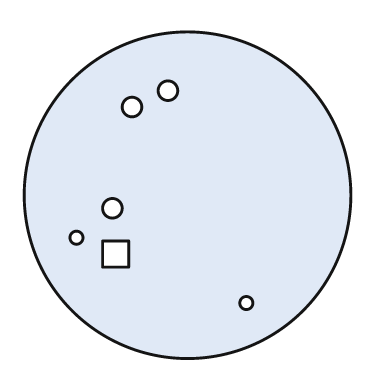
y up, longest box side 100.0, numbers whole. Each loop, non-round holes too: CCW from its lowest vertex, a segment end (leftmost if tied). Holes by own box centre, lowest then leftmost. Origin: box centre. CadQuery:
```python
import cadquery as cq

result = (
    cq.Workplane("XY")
    .moveTo(0.0, 0.0)
    .circle(50.0)
    .moveTo(18.0, -33.0)
    .circle(2.0)
    .moveTo(-26.0, -22.0)
    .lineTo(-18.0, -22.0)
    .lineTo(-18.0, -14.0)
    .lineTo(-26.0, -14.0)
    .close()
    .moveTo(-34.0, -13.0)
    .circle(2.0)
    .moveTo(-23.0, -4.0)
    .circle(3.0)
    .moveTo(-17.0, 27.0)
    .circle(3.0)
    .moveTo(-6.0, 32.0)
    .circle(3.0)
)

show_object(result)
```